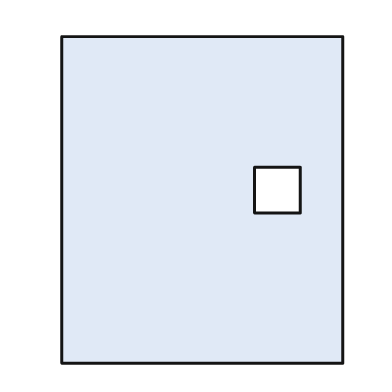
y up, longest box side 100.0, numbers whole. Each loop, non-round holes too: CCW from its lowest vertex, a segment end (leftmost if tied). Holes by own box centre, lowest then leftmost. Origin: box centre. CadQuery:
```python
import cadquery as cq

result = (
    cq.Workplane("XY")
    .moveTo(-43.0, -50.0)
    .lineTo(43.0, -50.0)
    .lineTo(43.0, 50.0)
    .lineTo(-43.0, 50.0)
    .close()
    .moveTo(16.0, -4.0)
    .lineTo(30.0, -4.0)
    .lineTo(30.0, 10.0)
    .lineTo(16.0, 10.0)
    .close()
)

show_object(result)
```